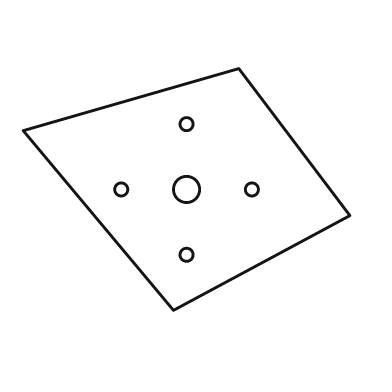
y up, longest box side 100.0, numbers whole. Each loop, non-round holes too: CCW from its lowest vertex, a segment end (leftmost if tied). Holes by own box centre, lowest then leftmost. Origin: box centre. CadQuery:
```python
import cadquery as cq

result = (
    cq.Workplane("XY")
    .moveTo(-4.0, -37.0)
    .lineTo(50.0, -8.0)
    .lineTo(16.0, 37.0)
    .lineTo(-50.0, 18.0)
    .close()
    .moveTo(0.0, -20.0)
    .circle(2.0)
    .moveTo(-20.0, 0.0)
    .circle(2.0)
    .moveTo(0.0, 0.0)
    .circle(4.0)
    .moveTo(20.0, 0.0)
    .circle(2.0)
    .moveTo(0.0, 20.0)
    .circle(2.0)
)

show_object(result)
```